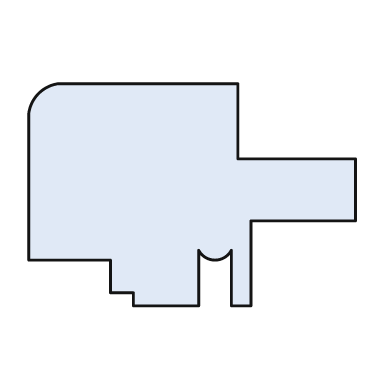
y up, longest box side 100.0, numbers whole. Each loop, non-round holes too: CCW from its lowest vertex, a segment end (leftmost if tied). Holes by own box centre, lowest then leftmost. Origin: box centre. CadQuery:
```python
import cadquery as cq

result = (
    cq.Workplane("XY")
    .moveTo(-18.0, -34.0)
    .lineTo(2.0, -34.0)
    .lineTo(2.0, -17.0)
    .threePointArc((7.0, -20.0), (12.0, -17.0))
    .lineTo(12.0, -34.0)
    .lineTo(18.0, -34.0)
    .lineTo(18.0, -8.0)
    .lineTo(50.0, -8.0)
    .lineTo(50.0, 11.0)
    .lineTo(14.0, 11.0)
    .lineTo(14.0, 34.0)
    .lineTo(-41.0, 34.0)
    .threePointArc((-47.0, 31.0), (-50.0, 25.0))
    .lineTo(-50.0, -20.0)
    .lineTo(-25.0, -20.0)
    .lineTo(-25.0, -30.0)
    .lineTo(-18.0, -30.0)
    .close()
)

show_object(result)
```